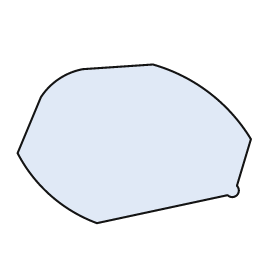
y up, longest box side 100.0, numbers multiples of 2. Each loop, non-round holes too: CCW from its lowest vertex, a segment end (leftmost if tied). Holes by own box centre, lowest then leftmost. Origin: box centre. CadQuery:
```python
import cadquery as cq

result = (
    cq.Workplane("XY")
    .moveTo(-16.0, -34.0)
    .lineTo(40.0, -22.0)
    .threePointArc((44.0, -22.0), (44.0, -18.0))
    .lineTo(50.0, 2.0)
    .threePointArc((32.0, 22.0), (8.0, 34.0))
    .lineTo(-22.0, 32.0)
    .threePointArc((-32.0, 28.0), (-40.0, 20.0))
    .lineTo(-50.0, -4.0)
    .threePointArc((-36.0, -22.0), (-16.0, -34.0))
    .close()
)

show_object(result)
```